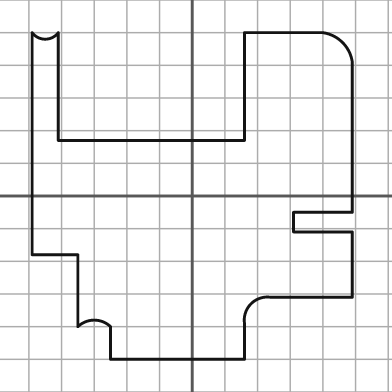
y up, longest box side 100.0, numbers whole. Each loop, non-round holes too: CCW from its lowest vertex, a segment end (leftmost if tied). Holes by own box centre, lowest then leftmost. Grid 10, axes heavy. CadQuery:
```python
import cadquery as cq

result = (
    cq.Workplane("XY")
    .moveTo(-25.0, -50.0)
    .lineTo(16.0, -50.0)
    .lineTo(16.0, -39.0)
    .threePointArc((18.0, -33.0), (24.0, -31.0))
    .lineTo(49.0, -31.0)
    .lineTo(49.0, -11.0)
    .lineTo(31.0, -11.0)
    .lineTo(31.0, -5.0)
    .lineTo(49.0, -5.0)
    .lineTo(49.0, 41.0)
    .threePointArc((46.0, 47.0), (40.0, 50.0))
    .lineTo(16.0, 50.0)
    .lineTo(16.0, 17.0)
    .lineTo(-41.0, 17.0)
    .lineTo(-41.0, 50.0)
    .threePointArc((-45.0, 48.0), (-49.0, 50.0))
    .lineTo(-49.0, -18.0)
    .lineTo(-35.0, -18.0)
    .lineTo(-35.0, -40.0)
    .threePointArc((-30.0, -38.0), (-25.0, -40.0))
    .close()
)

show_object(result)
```